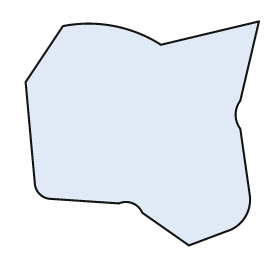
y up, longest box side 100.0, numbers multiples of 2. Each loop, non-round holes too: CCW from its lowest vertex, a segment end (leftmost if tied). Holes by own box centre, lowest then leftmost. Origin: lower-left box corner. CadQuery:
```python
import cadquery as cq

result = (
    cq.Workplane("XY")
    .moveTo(70.0, 0.0)
    .lineTo(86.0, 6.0)
    .threePointArc((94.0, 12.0), (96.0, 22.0))
    .lineTo(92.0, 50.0)
    .threePointArc((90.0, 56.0), (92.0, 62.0))
    .lineTo(100.0, 96.0)
    .lineTo(58.0, 86.0)
    .threePointArc((38.0, 94.0), (16.0, 94.0))
    .lineTo(0.0, 70.0)
    .lineTo(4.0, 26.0)
    .threePointArc((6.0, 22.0), (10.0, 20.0))
    .lineTo(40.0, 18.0)
    .threePointArc((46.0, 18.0), (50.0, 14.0))
    .close()
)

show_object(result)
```